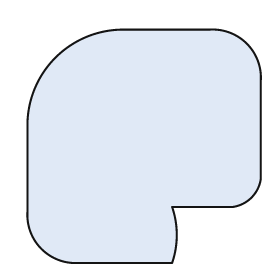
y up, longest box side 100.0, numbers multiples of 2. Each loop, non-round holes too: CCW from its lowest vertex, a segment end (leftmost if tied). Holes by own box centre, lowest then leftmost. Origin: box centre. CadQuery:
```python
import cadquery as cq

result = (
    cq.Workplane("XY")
    .moveTo(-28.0, -50.0)
    .lineTo(12.0, -50.0)
    .threePointArc((14.0, -38.0), (12.0, -26.0))
    .lineTo(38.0, -26.0)
    .threePointArc((46.0, -22.0), (50.0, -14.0))
    .lineTo(50.0, 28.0)
    .threePointArc((44.0, 44.0), (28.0, 50.0))
    .lineTo(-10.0, 50.0)
    .threePointArc((-38.0, 38.0), (-50.0, 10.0))
    .lineTo(-50.0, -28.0)
    .threePointArc((-44.0, -44.0), (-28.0, -50.0))
    .close()
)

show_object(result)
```